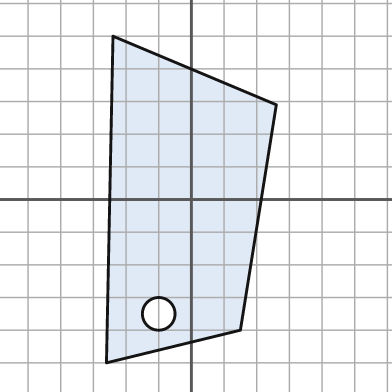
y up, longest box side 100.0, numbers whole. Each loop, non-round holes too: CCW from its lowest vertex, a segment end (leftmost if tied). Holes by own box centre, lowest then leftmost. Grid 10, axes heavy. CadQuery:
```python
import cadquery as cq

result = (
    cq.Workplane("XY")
    .moveTo(-26.0, -50.0)
    .lineTo(15.0, -40.0)
    .lineTo(26.0, 29.0)
    .lineTo(-24.0, 50.0)
    .close()
    .moveTo(-10.0, -35.0)
    .circle(5.0)
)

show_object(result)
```